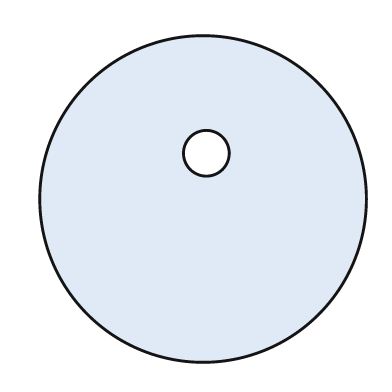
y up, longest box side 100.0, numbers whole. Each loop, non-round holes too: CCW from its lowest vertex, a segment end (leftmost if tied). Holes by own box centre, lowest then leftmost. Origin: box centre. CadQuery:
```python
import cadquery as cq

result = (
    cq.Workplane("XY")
    .moveTo(0.0, 0.0)
    .circle(50.0)
    .moveTo(1.0, 14.0)
    .circle(7.0)
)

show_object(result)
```